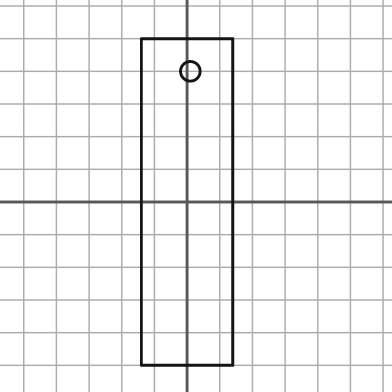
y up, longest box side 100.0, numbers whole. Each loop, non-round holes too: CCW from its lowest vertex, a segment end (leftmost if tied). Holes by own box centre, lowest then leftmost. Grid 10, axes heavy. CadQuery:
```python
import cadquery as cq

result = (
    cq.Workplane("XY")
    .moveTo(-14.0, -50.0)
    .lineTo(14.0, -50.0)
    .lineTo(14.0, 50.0)
    .lineTo(-14.0, 50.0)
    .close()
    .moveTo(1.0, 40.0)
    .circle(3.0)
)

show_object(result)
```